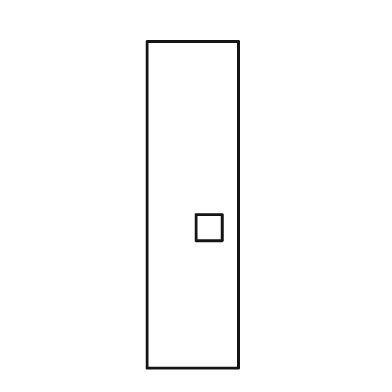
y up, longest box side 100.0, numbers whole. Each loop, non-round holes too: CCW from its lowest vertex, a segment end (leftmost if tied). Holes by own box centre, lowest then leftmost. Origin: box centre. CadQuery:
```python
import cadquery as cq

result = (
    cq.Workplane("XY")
    .moveTo(-14.0, -50.0)
    .lineTo(14.0, -50.0)
    .lineTo(14.0, 50.0)
    .lineTo(-14.0, 50.0)
    .close()
    .moveTo(1.0, -11.0)
    .lineTo(9.0, -11.0)
    .lineTo(9.0, -3.0)
    .lineTo(1.0, -3.0)
    .close()
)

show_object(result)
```